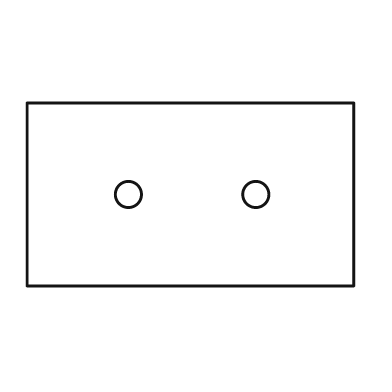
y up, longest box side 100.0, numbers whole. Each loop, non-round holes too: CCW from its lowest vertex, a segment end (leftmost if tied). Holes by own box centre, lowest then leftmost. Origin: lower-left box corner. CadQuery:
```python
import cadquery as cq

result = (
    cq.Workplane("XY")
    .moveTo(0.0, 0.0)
    .lineTo(100.0, 0.0)
    .lineTo(100.0, 56.0)
    .lineTo(0.0, 56.0)
    .close()
    .moveTo(31.0, 28.0)
    .circle(4.0)
    .moveTo(70.0, 28.0)
    .circle(4.0)
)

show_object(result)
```